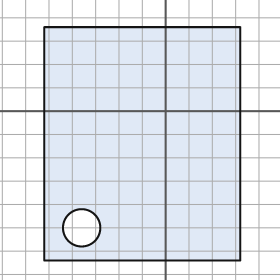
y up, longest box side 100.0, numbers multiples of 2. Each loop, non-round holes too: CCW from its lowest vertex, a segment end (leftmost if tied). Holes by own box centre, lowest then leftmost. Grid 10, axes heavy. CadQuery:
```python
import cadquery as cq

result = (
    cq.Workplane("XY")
    .moveTo(-52.0, -64.0)
    .lineTo(32.0, -64.0)
    .lineTo(32.0, 36.0)
    .lineTo(-52.0, 36.0)
    .close()
    .moveTo(-36.0, -50.0)
    .circle(8.0)
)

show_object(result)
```